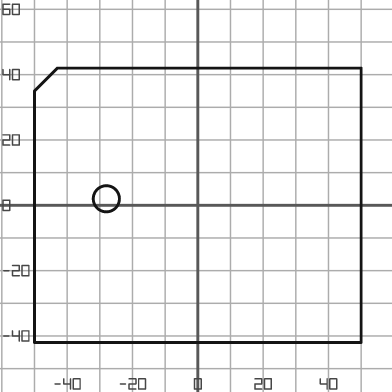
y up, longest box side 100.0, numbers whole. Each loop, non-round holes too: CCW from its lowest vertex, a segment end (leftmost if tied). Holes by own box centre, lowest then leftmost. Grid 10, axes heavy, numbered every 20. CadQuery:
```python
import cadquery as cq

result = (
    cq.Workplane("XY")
    .moveTo(-50.0, -42.0)
    .lineTo(50.0, -42.0)
    .lineTo(50.0, 42.0)
    .lineTo(-43.0, 42.0)
    .lineTo(-50.0, 35.0)
    .close()
    .moveTo(-28.0, 2.0)
    .circle(4.0)
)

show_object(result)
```